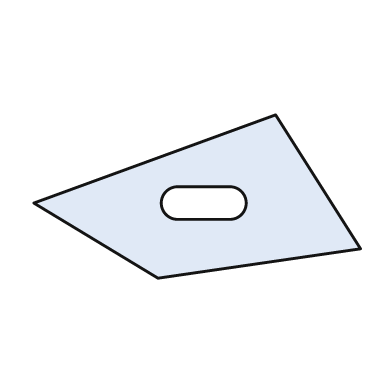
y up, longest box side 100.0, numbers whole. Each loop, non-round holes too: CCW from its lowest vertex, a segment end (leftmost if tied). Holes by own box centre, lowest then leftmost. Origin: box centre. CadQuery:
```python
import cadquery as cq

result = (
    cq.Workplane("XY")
    .moveTo(-12.0, -25.0)
    .lineTo(50.0, -16.0)
    .lineTo(24.0, 25.0)
    .lineTo(-50.0, -2.0)
    .close()
    .moveTo(-6.0, -7.0)
    .lineTo(10.0, -7.0)
    .threePointArc((15.0, -2.0), (10.0, 3.0))
    .lineTo(-6.0, 3.0)
    .threePointArc((-11.0, -2.0), (-6.0, -7.0))
    .close()
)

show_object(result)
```